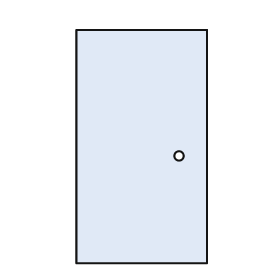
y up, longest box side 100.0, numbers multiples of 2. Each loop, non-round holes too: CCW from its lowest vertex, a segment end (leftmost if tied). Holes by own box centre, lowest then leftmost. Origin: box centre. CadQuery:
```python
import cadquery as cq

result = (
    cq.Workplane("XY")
    .moveTo(-28.0, -50.0)
    .lineTo(28.0, -50.0)
    .lineTo(28.0, 50.0)
    .lineTo(-28.0, 50.0)
    .close()
    .moveTo(16.0, -4.0)
    .circle(2.0)
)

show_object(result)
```